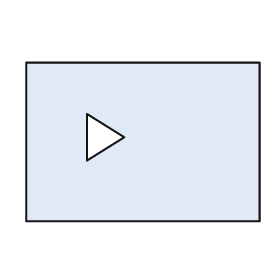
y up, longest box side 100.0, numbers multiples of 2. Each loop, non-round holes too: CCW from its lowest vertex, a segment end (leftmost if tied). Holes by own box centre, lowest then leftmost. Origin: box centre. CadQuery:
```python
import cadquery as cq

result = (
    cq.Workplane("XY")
    .moveTo(-50.0, -34.0)
    .lineTo(50.0, -34.0)
    .lineTo(50.0, 34.0)
    .lineTo(-50.0, 34.0)
    .close()
    .moveTo(-24.0, -8.0)
    .lineTo(-8.0, 2.0)
    .lineTo(-24.0, 12.0)
    .close()
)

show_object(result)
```